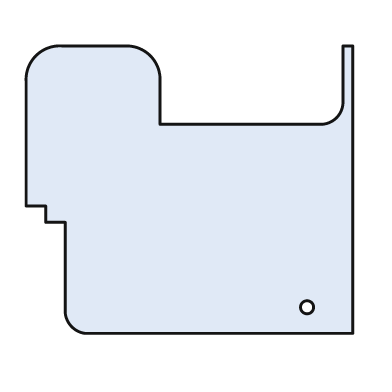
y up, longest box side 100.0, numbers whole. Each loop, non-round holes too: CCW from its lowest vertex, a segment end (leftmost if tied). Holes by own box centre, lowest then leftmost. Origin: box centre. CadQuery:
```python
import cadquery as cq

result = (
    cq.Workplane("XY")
    .moveTo(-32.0, -44.0)
    .lineTo(50.0, -44.0)
    .lineTo(50.0, 44.0)
    .lineTo(47.0, 44.0)
    .lineTo(47.0, 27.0)
    .threePointArc((45.0, 22.0), (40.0, 20.0))
    .lineTo(-9.0, 20.0)
    .lineTo(-9.0, 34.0)
    .threePointArc((-12.0, 41.0), (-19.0, 44.0))
    .lineTo(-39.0, 44.0)
    .threePointArc((-47.0, 41.0), (-50.0, 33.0))
    .lineTo(-50.0, -5.0)
    .lineTo(-44.0, -5.0)
    .lineTo(-44.0, -10.0)
    .lineTo(-38.0, -10.0)
    .lineTo(-38.0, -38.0)
    .threePointArc((-36.0, -42.0), (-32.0, -44.0))
    .close()
    .moveTo(36.0, -36.0)
    .circle(2.0)
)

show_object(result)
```